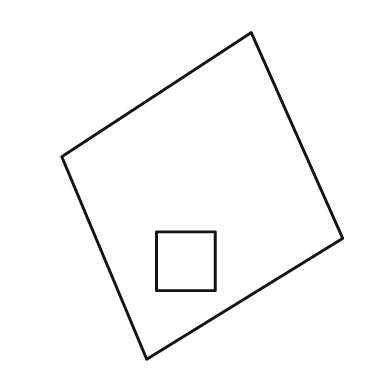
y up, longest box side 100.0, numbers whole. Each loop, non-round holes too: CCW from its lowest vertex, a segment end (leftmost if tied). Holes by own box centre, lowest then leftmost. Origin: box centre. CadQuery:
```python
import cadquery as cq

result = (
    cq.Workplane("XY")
    .moveTo(-17.0, -50.0)
    .lineTo(43.0, -13.0)
    .lineTo(15.0, 50.0)
    .lineTo(-43.0, 12.0)
    .close()
    .moveTo(-14.0, -29.0)
    .lineTo(4.0, -29.0)
    .lineTo(4.0, -11.0)
    .lineTo(-14.0, -11.0)
    .close()
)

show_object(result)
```